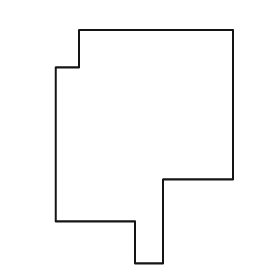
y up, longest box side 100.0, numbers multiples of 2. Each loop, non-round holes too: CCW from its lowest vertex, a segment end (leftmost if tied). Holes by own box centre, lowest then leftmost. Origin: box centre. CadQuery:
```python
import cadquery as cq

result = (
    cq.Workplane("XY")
    .moveTo(-4.0, -50.0)
    .lineTo(8.0, -50.0)
    .lineTo(8.0, -14.0)
    .lineTo(38.0, -14.0)
    .lineTo(38.0, 50.0)
    .lineTo(-28.0, 50.0)
    .lineTo(-28.0, 34.0)
    .lineTo(-38.0, 34.0)
    .lineTo(-38.0, -32.0)
    .lineTo(-4.0, -32.0)
    .close()
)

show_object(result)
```